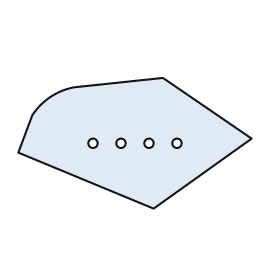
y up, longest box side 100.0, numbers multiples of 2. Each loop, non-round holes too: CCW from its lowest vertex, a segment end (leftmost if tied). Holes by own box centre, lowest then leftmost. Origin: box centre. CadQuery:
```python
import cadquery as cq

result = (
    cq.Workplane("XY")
    .moveTo(8.0, -28.0)
    .lineTo(50.0, 2.0)
    .lineTo(12.0, 28.0)
    .lineTo(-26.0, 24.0)
    .threePointArc((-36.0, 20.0), (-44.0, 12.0))
    .lineTo(-50.0, -4.0)
    .close()
    .moveTo(-18.0, 0.0)
    .circle(2.0)
    .moveTo(-6.0, 0.0)
    .circle(2.0)
    .moveTo(6.0, 0.0)
    .circle(2.0)
    .moveTo(18.0, 0.0)
    .circle(2.0)
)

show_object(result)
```